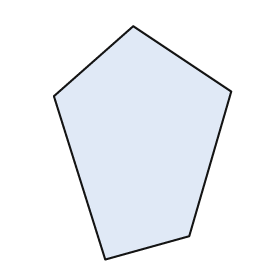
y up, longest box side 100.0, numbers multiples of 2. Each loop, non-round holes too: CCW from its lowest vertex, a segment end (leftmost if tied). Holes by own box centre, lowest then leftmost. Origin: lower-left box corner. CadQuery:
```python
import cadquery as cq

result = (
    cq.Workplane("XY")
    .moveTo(22.0, 0.0)
    .lineTo(58.0, 10.0)
    .lineTo(76.0, 72.0)
    .lineTo(34.0, 100.0)
    .lineTo(0.0, 70.0)
    .close()
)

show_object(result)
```